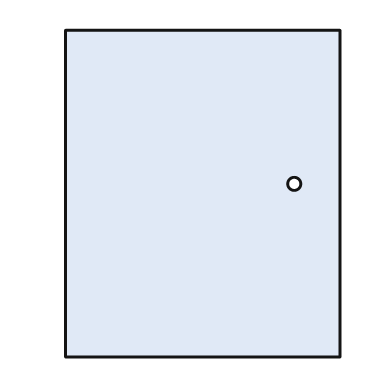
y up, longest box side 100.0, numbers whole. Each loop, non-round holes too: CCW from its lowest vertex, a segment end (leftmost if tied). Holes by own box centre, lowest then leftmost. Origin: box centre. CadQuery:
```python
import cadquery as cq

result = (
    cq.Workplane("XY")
    .moveTo(-42.0, -50.0)
    .lineTo(42.0, -50.0)
    .lineTo(42.0, 50.0)
    .lineTo(-42.0, 50.0)
    .close()
    .moveTo(28.0, 3.0)
    .circle(2.0)
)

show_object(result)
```